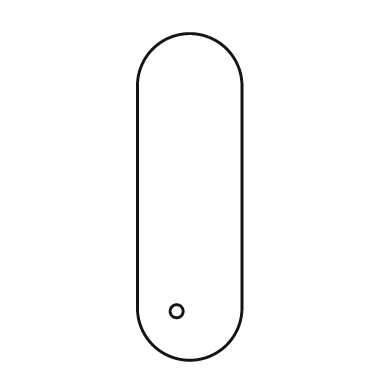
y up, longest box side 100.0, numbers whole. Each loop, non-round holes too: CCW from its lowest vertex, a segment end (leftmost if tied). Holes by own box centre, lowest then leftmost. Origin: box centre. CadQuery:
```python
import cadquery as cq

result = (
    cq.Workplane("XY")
    .moveTo(-16.0, -34.0)
    .threePointArc((0.0, -50.0), (16.0, -34.0))
    .lineTo(16.0, 34.0)
    .threePointArc((0.0, 50.0), (-16.0, 34.0))
    .close()
    .moveTo(-4.0, -35.0)
    .circle(2.0)
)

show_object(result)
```